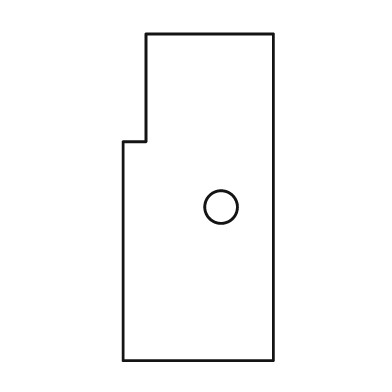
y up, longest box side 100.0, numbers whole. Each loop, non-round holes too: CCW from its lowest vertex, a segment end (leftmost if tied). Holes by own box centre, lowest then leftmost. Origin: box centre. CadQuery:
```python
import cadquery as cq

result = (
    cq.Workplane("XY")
    .moveTo(-23.0, -50.0)
    .lineTo(23.0, -50.0)
    .lineTo(23.0, 50.0)
    .lineTo(-16.0, 50.0)
    .lineTo(-16.0, 17.0)
    .lineTo(-23.0, 17.0)
    .close()
    .moveTo(7.0, -3.0)
    .circle(5.0)
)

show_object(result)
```